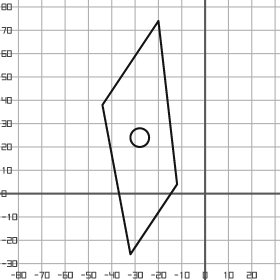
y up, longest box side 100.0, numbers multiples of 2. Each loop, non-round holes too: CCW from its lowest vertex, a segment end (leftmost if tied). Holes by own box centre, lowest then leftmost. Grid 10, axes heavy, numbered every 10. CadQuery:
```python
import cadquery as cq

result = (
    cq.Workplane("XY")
    .moveTo(-32.0, -26.0)
    .lineTo(-12.0, 4.0)
    .lineTo(-20.0, 74.0)
    .lineTo(-44.0, 38.0)
    .close()
    .moveTo(-28.0, 24.0)
    .circle(4.0)
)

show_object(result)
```